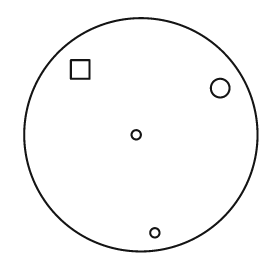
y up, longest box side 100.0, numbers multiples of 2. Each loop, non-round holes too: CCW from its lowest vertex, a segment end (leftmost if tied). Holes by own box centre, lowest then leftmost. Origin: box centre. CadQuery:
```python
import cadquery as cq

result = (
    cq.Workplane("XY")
    .moveTo(0.0, 0.0)
    .circle(50.0)
    .moveTo(6.0, -42.0)
    .circle(2.0)
    .moveTo(-2.0, 0.0)
    .circle(2.0)
    .moveTo(34.0, 20.0)
    .circle(4.0)
    .moveTo(-30.0, 24.0)
    .lineTo(-22.0, 24.0)
    .lineTo(-22.0, 32.0)
    .lineTo(-30.0, 32.0)
    .close()
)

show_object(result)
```